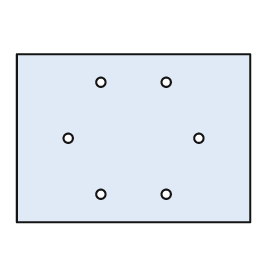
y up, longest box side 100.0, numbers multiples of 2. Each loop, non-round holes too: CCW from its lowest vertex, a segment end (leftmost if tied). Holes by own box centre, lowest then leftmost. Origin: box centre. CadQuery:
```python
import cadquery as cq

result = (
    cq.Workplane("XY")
    .moveTo(-50.0, -36.0)
    .lineTo(50.0, -36.0)
    .lineTo(50.0, 36.0)
    .lineTo(-50.0, 36.0)
    .close()
    .moveTo(-14.0, -24.0)
    .circle(2.0)
    .moveTo(14.0, -24.0)
    .circle(2.0)
    .moveTo(-28.0, 0.0)
    .circle(2.0)
    .moveTo(28.0, 0.0)
    .circle(2.0)
    .moveTo(-14.0, 24.0)
    .circle(2.0)
    .moveTo(14.0, 24.0)
    .circle(2.0)
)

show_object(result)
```